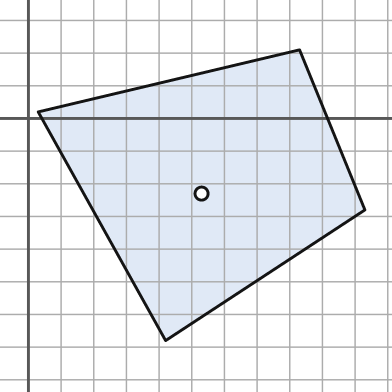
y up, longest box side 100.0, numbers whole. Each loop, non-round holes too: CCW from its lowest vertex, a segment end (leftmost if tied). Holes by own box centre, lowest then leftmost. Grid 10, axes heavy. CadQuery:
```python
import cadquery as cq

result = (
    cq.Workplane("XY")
    .moveTo(42.0, -68.0)
    .lineTo(103.0, -28.0)
    .lineTo(83.0, 21.0)
    .lineTo(3.0, 2.0)
    .close()
    .moveTo(53.0, -23.0)
    .circle(2.0)
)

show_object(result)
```